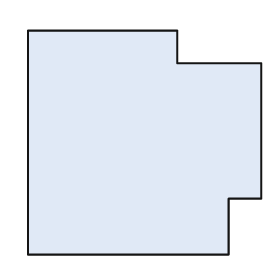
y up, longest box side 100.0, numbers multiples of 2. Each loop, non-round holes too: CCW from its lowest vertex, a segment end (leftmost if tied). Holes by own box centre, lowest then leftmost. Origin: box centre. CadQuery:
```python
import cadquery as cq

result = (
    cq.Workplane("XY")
    .moveTo(-50.0, -48.0)
    .lineTo(36.0, -48.0)
    .lineTo(36.0, -24.0)
    .lineTo(50.0, -24.0)
    .lineTo(50.0, 34.0)
    .lineTo(14.0, 34.0)
    .lineTo(14.0, 48.0)
    .lineTo(-50.0, 48.0)
    .close()
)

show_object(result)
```